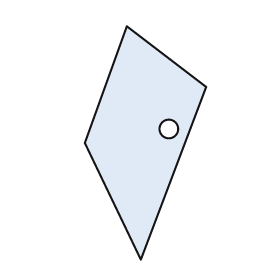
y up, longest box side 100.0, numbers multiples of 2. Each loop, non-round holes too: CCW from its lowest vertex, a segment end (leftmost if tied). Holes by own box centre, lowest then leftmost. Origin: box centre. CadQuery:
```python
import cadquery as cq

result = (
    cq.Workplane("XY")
    .moveTo(-2.0, -50.0)
    .lineTo(26.0, 24.0)
    .lineTo(-8.0, 50.0)
    .lineTo(-26.0, 0.0)
    .close()
    .moveTo(10.0, 6.0)
    .circle(4.0)
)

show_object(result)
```